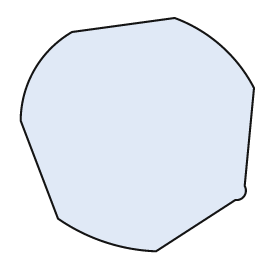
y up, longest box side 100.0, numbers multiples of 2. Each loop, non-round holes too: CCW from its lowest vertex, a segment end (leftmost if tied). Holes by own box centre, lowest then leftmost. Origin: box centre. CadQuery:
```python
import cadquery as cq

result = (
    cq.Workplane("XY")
    .moveTo(8.0, -50.0)
    .lineTo(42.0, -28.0)
    .threePointArc((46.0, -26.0), (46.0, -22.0))
    .lineTo(50.0, 20.0)
    .threePointArc((36.0, 38.0), (16.0, 50.0))
    .lineTo(-28.0, 44.0)
    .threePointArc((-44.0, 28.0), (-50.0, 6.0))
    .lineTo(-34.0, -36.0)
    .threePointArc((-14.0, -46.0), (8.0, -50.0))
    .close()
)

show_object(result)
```